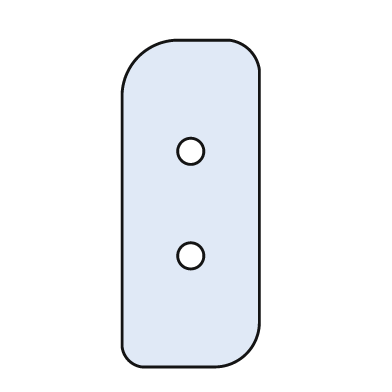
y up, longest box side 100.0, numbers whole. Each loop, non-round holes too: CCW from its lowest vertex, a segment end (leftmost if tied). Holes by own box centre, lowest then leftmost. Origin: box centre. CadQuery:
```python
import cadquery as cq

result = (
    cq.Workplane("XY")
    .moveTo(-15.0, -50.0)
    .lineTo(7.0, -50.0)
    .threePointArc((17.0, -46.0), (21.0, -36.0))
    .lineTo(21.0, 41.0)
    .threePointArc((18.0, 47.0), (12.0, 50.0))
    .lineTo(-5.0, 50.0)
    .threePointArc((-16.0, 45.0), (-21.0, 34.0))
    .lineTo(-21.0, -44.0)
    .threePointArc((-19.0, -48.0), (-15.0, -50.0))
    .close()
    .moveTo(0.0, -16.0)
    .circle(4.0)
    .moveTo(0.0, 16.0)
    .circle(4.0)
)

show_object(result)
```